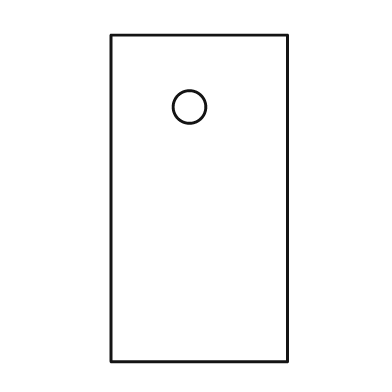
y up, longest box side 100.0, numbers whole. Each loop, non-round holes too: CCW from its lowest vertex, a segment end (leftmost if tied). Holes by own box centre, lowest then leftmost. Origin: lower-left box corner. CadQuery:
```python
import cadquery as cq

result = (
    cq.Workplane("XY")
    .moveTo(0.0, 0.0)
    .lineTo(54.0, 0.0)
    .lineTo(54.0, 100.0)
    .lineTo(0.0, 100.0)
    .close()
    .moveTo(24.0, 78.0)
    .circle(5.0)
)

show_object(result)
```